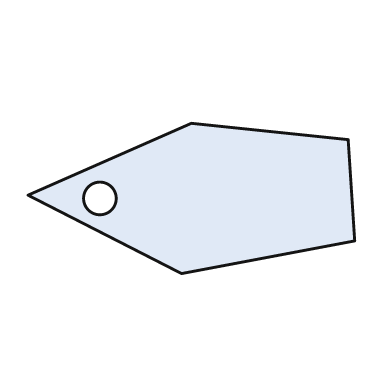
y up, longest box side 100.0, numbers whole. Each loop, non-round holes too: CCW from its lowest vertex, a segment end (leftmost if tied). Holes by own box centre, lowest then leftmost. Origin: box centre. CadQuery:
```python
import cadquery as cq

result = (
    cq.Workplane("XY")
    .moveTo(-3.0, -23.0)
    .lineTo(50.0, -13.0)
    .lineTo(48.0, 18.0)
    .lineTo(0.0, 23.0)
    .lineTo(-50.0, 1.0)
    .close()
    .moveTo(-28.0, 0.0)
    .circle(5.0)
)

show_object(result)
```